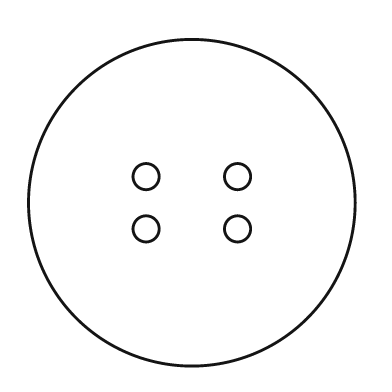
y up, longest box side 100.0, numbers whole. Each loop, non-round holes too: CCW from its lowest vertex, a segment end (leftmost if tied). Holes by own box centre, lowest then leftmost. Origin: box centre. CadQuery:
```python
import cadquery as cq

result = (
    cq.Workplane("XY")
    .moveTo(0.0, 0.0)
    .circle(50.0)
    .moveTo(-14.0, -8.0)
    .circle(4.0)
    .moveTo(14.0, -8.0)
    .circle(4.0)
    .moveTo(-14.0, 8.0)
    .circle(4.0)
    .moveTo(14.0, 8.0)
    .circle(4.0)
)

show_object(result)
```